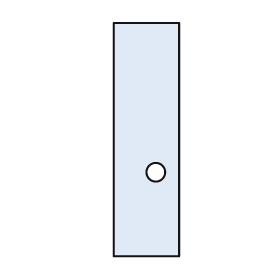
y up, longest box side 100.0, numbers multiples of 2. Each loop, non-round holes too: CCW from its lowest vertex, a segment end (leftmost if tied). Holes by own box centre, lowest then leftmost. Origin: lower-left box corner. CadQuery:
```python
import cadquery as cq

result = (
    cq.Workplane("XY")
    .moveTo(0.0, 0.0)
    .lineTo(28.0, 0.0)
    .lineTo(28.0, 100.0)
    .lineTo(0.0, 100.0)
    .close()
    .moveTo(18.0, 36.0)
    .circle(4.0)
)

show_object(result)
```